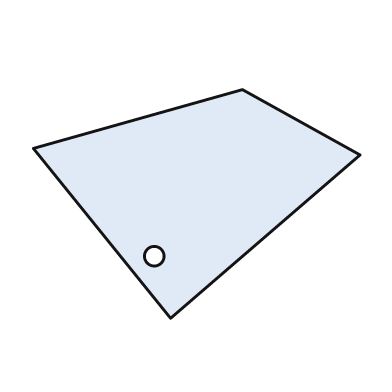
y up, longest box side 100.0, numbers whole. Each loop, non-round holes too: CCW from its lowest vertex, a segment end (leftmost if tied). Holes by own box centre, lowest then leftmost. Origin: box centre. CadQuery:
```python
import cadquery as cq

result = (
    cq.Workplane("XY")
    .moveTo(-8.0, -35.0)
    .lineTo(50.0, 15.0)
    .lineTo(14.0, 35.0)
    .lineTo(-50.0, 17.0)
    .close()
    .moveTo(-13.0, -16.0)
    .circle(3.0)
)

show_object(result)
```